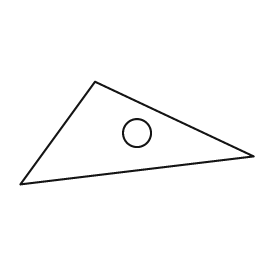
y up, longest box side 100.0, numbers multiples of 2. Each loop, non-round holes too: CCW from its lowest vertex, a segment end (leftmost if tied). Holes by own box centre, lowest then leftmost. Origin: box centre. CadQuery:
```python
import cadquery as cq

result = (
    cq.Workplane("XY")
    .moveTo(-50.0, -22.0)
    .lineTo(50.0, -10.0)
    .lineTo(-18.0, 22.0)
    .close()
    .moveTo(0.0, 0.0)
    .circle(6.0)
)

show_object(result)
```